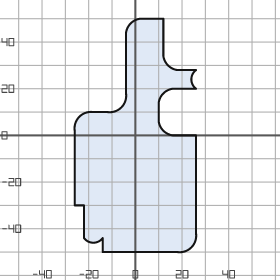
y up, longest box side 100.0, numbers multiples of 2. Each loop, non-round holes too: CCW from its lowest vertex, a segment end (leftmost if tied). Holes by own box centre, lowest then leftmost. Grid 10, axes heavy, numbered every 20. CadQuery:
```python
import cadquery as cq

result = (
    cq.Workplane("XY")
    .moveTo(-14.0, -50.0)
    .lineTo(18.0, -50.0)
    .threePointArc((24.0, -48.0), (26.0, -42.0))
    .lineTo(26.0, 0.0)
    .lineTo(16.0, 0.0)
    .threePointArc((12.0, 2.0), (10.0, 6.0))
    .lineTo(10.0, 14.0)
    .threePointArc((12.0, 18.0), (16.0, 20.0))
    .lineTo(26.0, 20.0)
    .threePointArc((24.0, 24.0), (26.0, 28.0))
    .lineTo(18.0, 28.0)
    .threePointArc((14.0, 30.0), (12.0, 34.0))
    .lineTo(12.0, 50.0)
    .lineTo(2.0, 50.0)
    .threePointArc((-2.0, 48.0), (-4.0, 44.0))
    .lineTo(-4.0, 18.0)
    .threePointArc((-6.0, 12.0), (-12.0, 10.0))
    .lineTo(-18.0, 10.0)
    .threePointArc((-24.0, 8.0), (-26.0, 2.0))
    .lineTo(-26.0, -30.0)
    .lineTo(-22.0, -30.0)
    .lineTo(-22.0, -44.0)
    .threePointArc((-18.0, -46.0), (-14.0, -44.0))
    .close()
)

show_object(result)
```